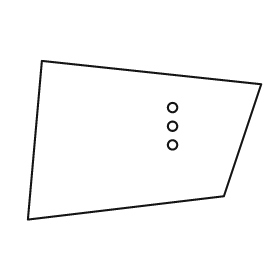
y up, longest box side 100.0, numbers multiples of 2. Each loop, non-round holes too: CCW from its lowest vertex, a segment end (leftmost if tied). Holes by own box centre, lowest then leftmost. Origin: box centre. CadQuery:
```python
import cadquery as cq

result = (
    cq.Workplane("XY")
    .moveTo(-50.0, -34.0)
    .lineTo(34.0, -24.0)
    .lineTo(50.0, 24.0)
    .lineTo(-44.0, 34.0)
    .close()
    .moveTo(12.0, -2.0)
    .circle(2.0)
    .moveTo(12.0, 6.0)
    .circle(2.0)
    .moveTo(12.0, 14.0)
    .circle(2.0)
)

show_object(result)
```